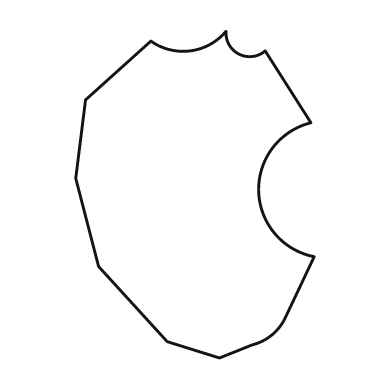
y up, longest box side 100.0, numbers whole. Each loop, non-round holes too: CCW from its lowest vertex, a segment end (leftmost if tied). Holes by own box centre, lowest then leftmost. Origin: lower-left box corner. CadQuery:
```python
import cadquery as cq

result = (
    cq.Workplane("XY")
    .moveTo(44.0, 0.0)
    .lineTo(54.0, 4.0)
    .threePointArc((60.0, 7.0), (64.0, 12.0))
    .lineTo(73.0, 31.0)
    .threePointArc((56.0, 51.0), (72.0, 72.0))
    .lineTo(58.0, 94.0)
    .threePointArc((50.0, 93.0), (46.0, 100.0))
    .threePointArc((35.0, 94.0), (23.0, 97.0))
    .lineTo(3.0, 79.0)
    .lineTo(0.0, 55.0)
    .lineTo(7.0, 28.0)
    .lineTo(28.0, 5.0)
    .close()
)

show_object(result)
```